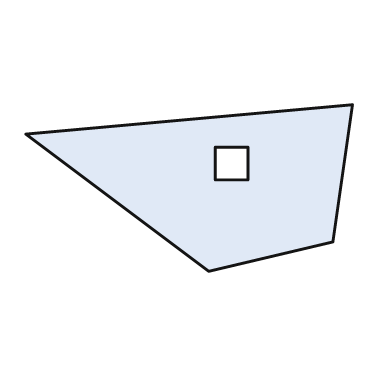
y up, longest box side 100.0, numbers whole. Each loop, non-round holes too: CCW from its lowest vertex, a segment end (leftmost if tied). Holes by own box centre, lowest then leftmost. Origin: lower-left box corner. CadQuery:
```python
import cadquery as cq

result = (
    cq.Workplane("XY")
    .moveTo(56.0, 0.0)
    .lineTo(94.0, 9.0)
    .lineTo(100.0, 51.0)
    .lineTo(0.0, 42.0)
    .close()
    .moveTo(58.0, 28.0)
    .lineTo(68.0, 28.0)
    .lineTo(68.0, 38.0)
    .lineTo(58.0, 38.0)
    .close()
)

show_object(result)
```